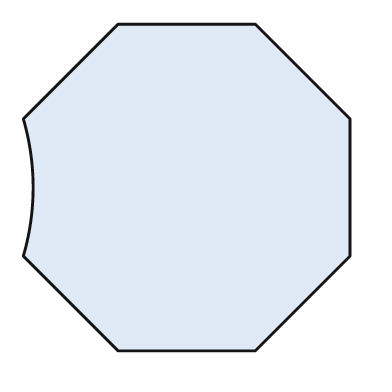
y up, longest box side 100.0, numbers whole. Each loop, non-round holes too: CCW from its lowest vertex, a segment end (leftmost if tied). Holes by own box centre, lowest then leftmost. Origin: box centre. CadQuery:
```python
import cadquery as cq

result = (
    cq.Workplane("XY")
    .moveTo(-21.0, -50.0)
    .lineTo(21.0, -50.0)
    .lineTo(50.0, -21.0)
    .lineTo(50.0, 21.0)
    .lineTo(21.0, 50.0)
    .lineTo(-21.0, 50.0)
    .lineTo(-50.0, 21.0)
    .threePointArc((-47.0, 0.0), (-50.0, -21.0))
    .close()
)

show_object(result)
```